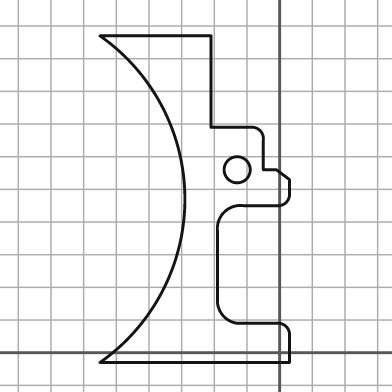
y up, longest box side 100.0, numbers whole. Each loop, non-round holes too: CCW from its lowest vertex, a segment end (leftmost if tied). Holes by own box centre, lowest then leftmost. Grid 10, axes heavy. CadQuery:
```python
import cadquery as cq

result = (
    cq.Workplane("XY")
    .moveTo(-55.0, -3.0)
    .lineTo(3.0, -3.0)
    .lineTo(3.0, 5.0)
    .threePointArc((2.0, 8.0), (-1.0, 9.0))
    .lineTo(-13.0, 9.0)
    .threePointArc((-17.0, 11.0), (-19.0, 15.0))
    .lineTo(-19.0, 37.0)
    .threePointArc((-17.0, 43.0), (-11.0, 45.0))
    .lineTo(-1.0, 45.0)
    .threePointArc((2.0, 46.0), (3.0, 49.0))
    .lineTo(3.0, 53.0)
    .lineTo(-1.0, 56.0)
    .lineTo(-5.0, 56.0)
    .lineTo(-5.0, 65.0)
    .threePointArc((-6.0, 68.0), (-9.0, 69.0))
    .lineTo(-21.0, 69.0)
    .lineTo(-21.0, 97.0)
    .lineTo(-55.0, 97.0)
    .threePointArc((-29.0, 47.0), (-55.0, -3.0))
    .close()
    .moveTo(-13.0, 56.0)
    .circle(4.0)
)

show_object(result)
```